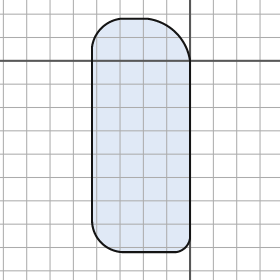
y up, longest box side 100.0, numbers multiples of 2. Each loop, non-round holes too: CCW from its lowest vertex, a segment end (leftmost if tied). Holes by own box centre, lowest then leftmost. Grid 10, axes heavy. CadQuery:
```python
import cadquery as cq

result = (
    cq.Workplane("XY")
    .moveTo(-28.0, -82.0)
    .lineTo(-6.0, -82.0)
    .threePointArc((-2.0, -80.0), (0.0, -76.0))
    .lineTo(0.0, 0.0)
    .threePointArc((-6.0, 12.0), (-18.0, 18.0))
    .lineTo(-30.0, 18.0)
    .threePointArc((-38.0, 14.0), (-42.0, 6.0))
    .lineTo(-42.0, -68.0)
    .threePointArc((-38.0, -78.0), (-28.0, -82.0))
    .close()
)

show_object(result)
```